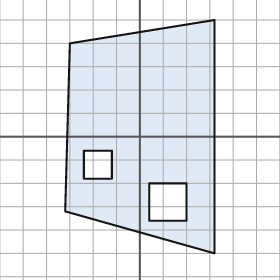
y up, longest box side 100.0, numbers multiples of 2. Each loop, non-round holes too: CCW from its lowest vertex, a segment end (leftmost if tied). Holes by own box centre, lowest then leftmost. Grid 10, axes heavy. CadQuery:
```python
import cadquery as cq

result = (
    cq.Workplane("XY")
    .moveTo(32.0, -50.0)
    .lineTo(32.0, 50.0)
    .lineTo(-30.0, 40.0)
    .lineTo(-32.0, -32.0)
    .close()
    .moveTo(4.0, -36.0)
    .lineTo(20.0, -36.0)
    .lineTo(20.0, -20.0)
    .lineTo(4.0, -20.0)
    .close()
    .moveTo(-24.0, -18.0)
    .lineTo(-12.0, -18.0)
    .lineTo(-12.0, -6.0)
    .lineTo(-24.0, -6.0)
    .close()
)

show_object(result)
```